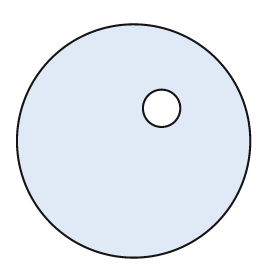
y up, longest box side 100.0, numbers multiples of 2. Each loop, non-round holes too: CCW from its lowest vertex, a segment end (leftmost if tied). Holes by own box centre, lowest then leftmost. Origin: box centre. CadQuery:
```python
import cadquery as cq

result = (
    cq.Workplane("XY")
    .moveTo(0.0, 0.0)
    .circle(50.0)
    .moveTo(12.0, 14.0)
    .circle(8.0)
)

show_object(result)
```